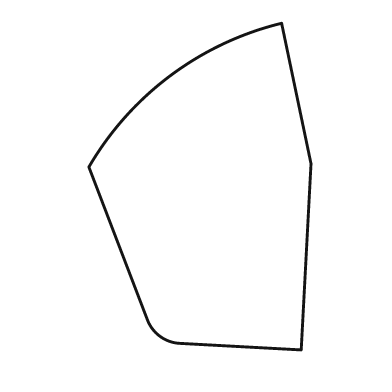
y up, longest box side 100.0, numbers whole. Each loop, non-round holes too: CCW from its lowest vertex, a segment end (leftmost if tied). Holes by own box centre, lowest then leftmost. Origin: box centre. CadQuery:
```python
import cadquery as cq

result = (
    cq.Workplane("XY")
    .moveTo(31.0, -50.0)
    .lineTo(34.0, 7.0)
    .lineTo(25.0, 50.0)
    .threePointArc((-9.0, 34.0), (-34.0, 6.0))
    .lineTo(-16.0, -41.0)
    .threePointArc((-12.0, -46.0), (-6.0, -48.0))
    .close()
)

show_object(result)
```